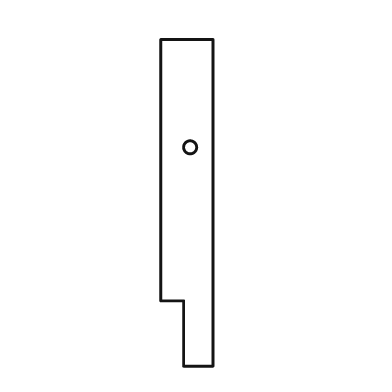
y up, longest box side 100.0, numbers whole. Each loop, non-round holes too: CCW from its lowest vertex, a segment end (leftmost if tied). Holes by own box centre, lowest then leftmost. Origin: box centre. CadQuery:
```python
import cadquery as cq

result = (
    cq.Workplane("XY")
    .moveTo(-1.0, -50.0)
    .lineTo(8.0, -50.0)
    .lineTo(8.0, 50.0)
    .lineTo(-8.0, 50.0)
    .lineTo(-8.0, -30.0)
    .lineTo(-1.0, -30.0)
    .close()
    .moveTo(1.0, 17.0)
    .circle(2.0)
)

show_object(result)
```